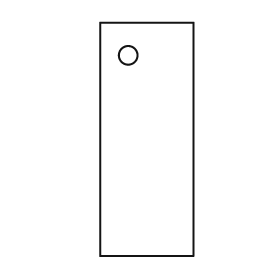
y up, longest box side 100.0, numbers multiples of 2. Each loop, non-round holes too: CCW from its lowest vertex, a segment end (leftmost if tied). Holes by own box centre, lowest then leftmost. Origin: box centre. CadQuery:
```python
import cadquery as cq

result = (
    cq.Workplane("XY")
    .moveTo(-20.0, -50.0)
    .lineTo(20.0, -50.0)
    .lineTo(20.0, 50.0)
    .lineTo(-20.0, 50.0)
    .close()
    .moveTo(-8.0, 36.0)
    .circle(4.0)
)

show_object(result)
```